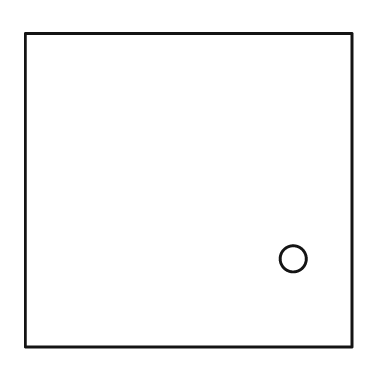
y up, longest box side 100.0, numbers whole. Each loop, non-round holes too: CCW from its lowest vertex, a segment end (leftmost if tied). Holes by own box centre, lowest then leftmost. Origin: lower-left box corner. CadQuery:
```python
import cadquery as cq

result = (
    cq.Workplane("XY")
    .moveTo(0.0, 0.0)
    .lineTo(100.0, 0.0)
    .lineTo(100.0, 96.0)
    .lineTo(0.0, 96.0)
    .close()
    .moveTo(82.0, 27.0)
    .circle(4.0)
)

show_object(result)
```